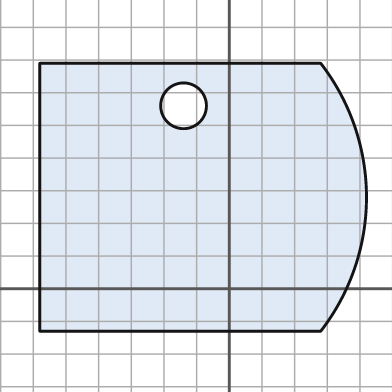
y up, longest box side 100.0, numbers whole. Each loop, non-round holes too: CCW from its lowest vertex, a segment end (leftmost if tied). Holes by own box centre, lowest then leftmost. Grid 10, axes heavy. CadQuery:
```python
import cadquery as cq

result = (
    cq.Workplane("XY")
    .moveTo(-58.0, -13.0)
    .lineTo(28.0, -13.0)
    .threePointArc((42.0, 28.0), (28.0, 69.0))
    .lineTo(-58.0, 69.0)
    .close()
    .moveTo(-14.0, 56.0)
    .circle(7.0)
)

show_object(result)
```